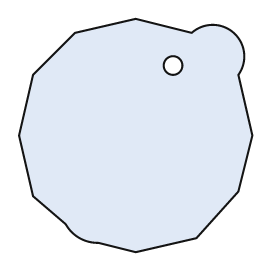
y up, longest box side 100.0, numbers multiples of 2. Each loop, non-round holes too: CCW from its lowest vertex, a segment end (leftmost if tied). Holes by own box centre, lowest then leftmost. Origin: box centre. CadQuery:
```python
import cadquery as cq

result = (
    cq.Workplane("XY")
    .moveTo(0.0, -50.0)
    .lineTo(26.0, -44.0)
    .lineTo(44.0, -24.0)
    .lineTo(50.0, 0.0)
    .lineTo(44.0, 26.0)
    .threePointArc((42.0, 44.0), (24.0, 44.0))
    .lineTo(0.0, 50.0)
    .lineTo(-26.0, 44.0)
    .lineTo(-44.0, 26.0)
    .lineTo(-50.0, 0.0)
    .lineTo(-44.0, -26.0)
    .lineTo(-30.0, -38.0)
    .threePointArc((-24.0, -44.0), (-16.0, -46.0))
    .close()
    .moveTo(16.0, 30.0)
    .circle(4.0)
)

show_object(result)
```